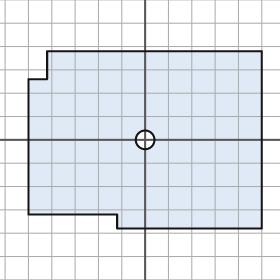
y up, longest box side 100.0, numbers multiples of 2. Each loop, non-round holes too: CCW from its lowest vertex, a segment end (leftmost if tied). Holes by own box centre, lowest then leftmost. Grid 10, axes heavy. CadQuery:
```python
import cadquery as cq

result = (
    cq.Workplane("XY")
    .moveTo(-12.0, -38.0)
    .lineTo(50.0, -38.0)
    .lineTo(50.0, 38.0)
    .lineTo(-42.0, 38.0)
    .lineTo(-42.0, 26.0)
    .lineTo(-50.0, 26.0)
    .lineTo(-50.0, -32.0)
    .lineTo(-12.0, -32.0)
    .close()
    .moveTo(0.0, 0.0)
    .circle(4.0)
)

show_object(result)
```